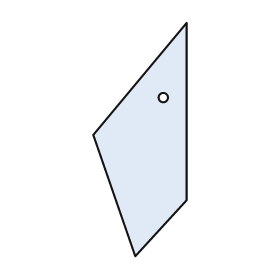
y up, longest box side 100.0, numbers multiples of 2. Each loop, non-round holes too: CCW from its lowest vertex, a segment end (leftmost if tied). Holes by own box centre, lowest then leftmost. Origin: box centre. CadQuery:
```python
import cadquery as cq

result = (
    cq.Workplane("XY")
    .moveTo(-2.0, -50.0)
    .lineTo(20.0, -26.0)
    .lineTo(20.0, 50.0)
    .lineTo(-20.0, 2.0)
    .close()
    .moveTo(10.0, 18.0)
    .circle(2.0)
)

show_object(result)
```